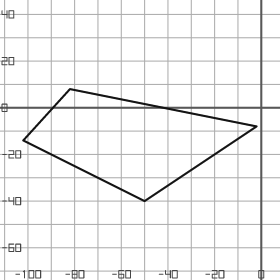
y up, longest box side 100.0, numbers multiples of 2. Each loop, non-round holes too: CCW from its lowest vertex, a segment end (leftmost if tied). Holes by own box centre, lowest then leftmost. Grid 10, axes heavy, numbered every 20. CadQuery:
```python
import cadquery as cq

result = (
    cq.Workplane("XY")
    .moveTo(-50.0, -40.0)
    .lineTo(-2.0, -8.0)
    .lineTo(-82.0, 8.0)
    .lineTo(-102.0, -14.0)
    .close()
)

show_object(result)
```